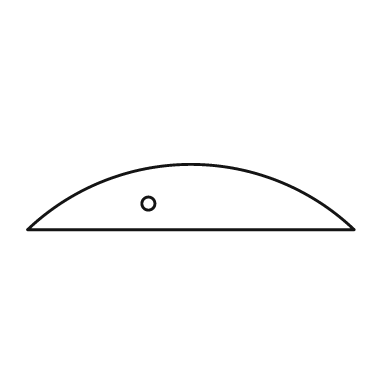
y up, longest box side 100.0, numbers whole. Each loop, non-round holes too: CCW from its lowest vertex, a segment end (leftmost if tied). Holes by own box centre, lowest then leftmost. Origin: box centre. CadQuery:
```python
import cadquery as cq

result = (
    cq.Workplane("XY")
    .moveTo(-50.0, -10.0)
    .lineTo(50.0, -10.0)
    .threePointArc((0.0, 10.0), (-50.0, -10.0))
    .close()
    .moveTo(-13.0, -2.0)
    .circle(2.0)
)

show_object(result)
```